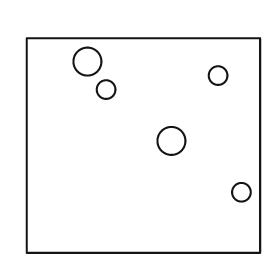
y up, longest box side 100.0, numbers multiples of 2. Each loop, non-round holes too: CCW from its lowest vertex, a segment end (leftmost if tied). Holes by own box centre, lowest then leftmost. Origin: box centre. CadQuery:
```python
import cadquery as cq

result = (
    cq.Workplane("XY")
    .moveTo(-50.0, -46.0)
    .lineTo(50.0, -46.0)
    .lineTo(50.0, 46.0)
    .lineTo(-50.0, 46.0)
    .close()
    .moveTo(42.0, -20.0)
    .circle(4.0)
    .moveTo(12.0, 2.0)
    .circle(6.0)
    .moveTo(-16.0, 24.0)
    .circle(4.0)
    .moveTo(32.0, 30.0)
    .circle(4.0)
    .moveTo(-24.0, 36.0)
    .circle(6.0)
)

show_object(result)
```